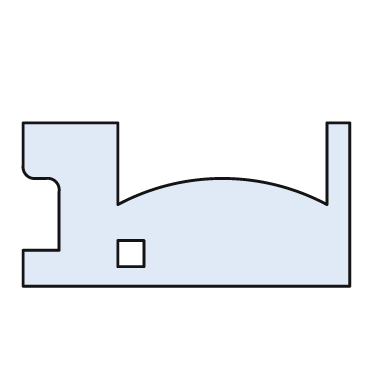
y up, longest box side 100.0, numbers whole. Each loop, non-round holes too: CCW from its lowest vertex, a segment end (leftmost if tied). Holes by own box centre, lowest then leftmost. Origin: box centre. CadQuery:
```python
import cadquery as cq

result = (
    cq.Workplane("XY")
    .moveTo(-50.0, -25.0)
    .lineTo(50.0, -25.0)
    .lineTo(50.0, 25.0)
    .lineTo(43.0, 25.0)
    .lineTo(43.0, 0.0)
    .threePointArc((11.0, 8.0), (-21.0, 0.0))
    .lineTo(-21.0, 25.0)
    .lineTo(-50.0, 25.0)
    .lineTo(-50.0, 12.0)
    .threePointArc((-49.0, 9.0), (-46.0, 8.0))
    .lineTo(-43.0, 8.0)
    .threePointArc((-40.0, 7.0), (-39.0, 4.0))
    .lineTo(-39.0, -14.0)
    .lineTo(-50.0, -14.0)
    .close()
    .moveTo(-21.0, -19.0)
    .lineTo(-13.0, -19.0)
    .lineTo(-13.0, -11.0)
    .lineTo(-21.0, -11.0)
    .close()
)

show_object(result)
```